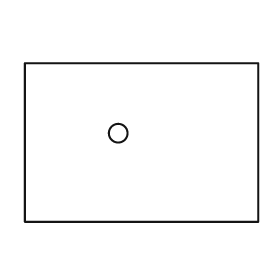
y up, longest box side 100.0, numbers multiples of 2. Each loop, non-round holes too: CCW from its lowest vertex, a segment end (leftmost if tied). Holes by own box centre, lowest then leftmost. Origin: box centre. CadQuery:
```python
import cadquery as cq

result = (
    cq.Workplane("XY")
    .moveTo(-50.0, -34.0)
    .lineTo(50.0, -34.0)
    .lineTo(50.0, 34.0)
    .lineTo(-50.0, 34.0)
    .close()
    .moveTo(-10.0, 4.0)
    .circle(4.0)
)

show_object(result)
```